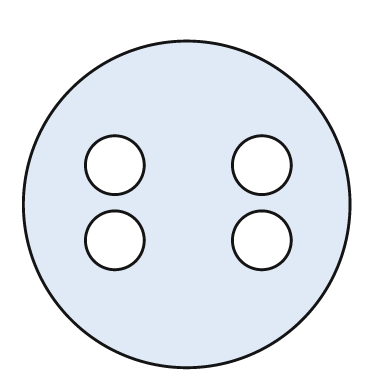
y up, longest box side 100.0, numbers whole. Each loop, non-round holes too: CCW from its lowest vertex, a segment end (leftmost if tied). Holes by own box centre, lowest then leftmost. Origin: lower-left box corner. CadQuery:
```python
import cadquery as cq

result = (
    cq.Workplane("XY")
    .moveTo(50.0, 50.0)
    .circle(50.0)
    .moveTo(28.0, 39.0)
    .circle(9.0)
    .moveTo(73.0, 39.0)
    .circle(9.0)
    .moveTo(28.0, 62.0)
    .circle(9.0)
    .moveTo(73.0, 62.0)
    .circle(9.0)
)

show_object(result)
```